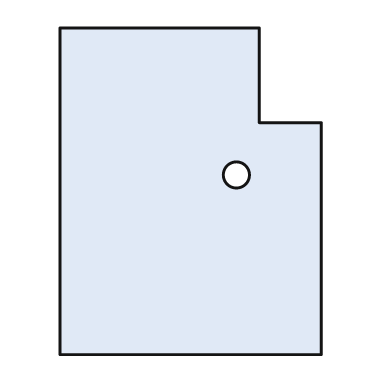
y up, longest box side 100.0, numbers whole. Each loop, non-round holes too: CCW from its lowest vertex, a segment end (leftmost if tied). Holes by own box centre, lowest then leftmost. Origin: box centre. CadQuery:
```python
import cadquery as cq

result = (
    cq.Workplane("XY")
    .moveTo(-40.0, -50.0)
    .lineTo(40.0, -50.0)
    .lineTo(40.0, 21.0)
    .lineTo(21.0, 21.0)
    .lineTo(21.0, 50.0)
    .lineTo(-40.0, 50.0)
    .close()
    .moveTo(14.0, 5.0)
    .circle(4.0)
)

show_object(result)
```